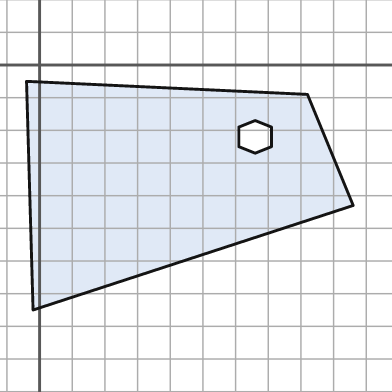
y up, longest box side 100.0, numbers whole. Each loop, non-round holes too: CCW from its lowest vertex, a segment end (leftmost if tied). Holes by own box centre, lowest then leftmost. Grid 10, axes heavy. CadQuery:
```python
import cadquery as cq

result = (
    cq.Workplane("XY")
    .moveTo(-2.0, -75.0)
    .lineTo(96.0, -43.0)
    .lineTo(82.0, -9.0)
    .lineTo(-4.0, -5.0)
    .close()
    .moveTo(66.0, -27.0)
    .lineTo(71.0, -25.0)
    .lineTo(71.0, -19.0)
    .lineTo(66.0, -17.0)
    .lineTo(61.0, -19.0)
    .lineTo(61.0, -25.0)
    .close()
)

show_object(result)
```